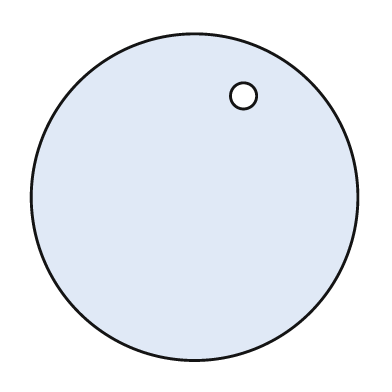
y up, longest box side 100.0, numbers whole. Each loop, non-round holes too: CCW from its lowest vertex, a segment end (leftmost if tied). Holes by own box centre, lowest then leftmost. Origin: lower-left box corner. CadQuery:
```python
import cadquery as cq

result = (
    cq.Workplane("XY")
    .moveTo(50.0, 50.0)
    .circle(50.0)
    .moveTo(65.0, 81.0)
    .circle(4.0)
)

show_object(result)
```